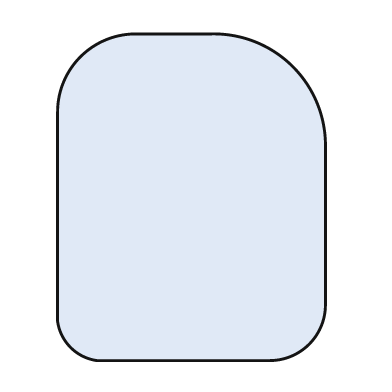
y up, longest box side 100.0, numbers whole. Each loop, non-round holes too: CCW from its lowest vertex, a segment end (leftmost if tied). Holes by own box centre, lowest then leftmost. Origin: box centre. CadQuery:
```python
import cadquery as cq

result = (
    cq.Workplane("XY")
    .moveTo(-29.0, -50.0)
    .lineTo(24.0, -50.0)
    .threePointArc((36.0, -45.0), (41.0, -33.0))
    .lineTo(41.0, 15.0)
    .threePointArc((31.0, 40.0), (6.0, 50.0))
    .lineTo(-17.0, 50.0)
    .threePointArc((-34.0, 43.0), (-41.0, 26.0))
    .lineTo(-41.0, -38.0)
    .threePointArc((-37.0, -46.0), (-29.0, -50.0))
    .close()
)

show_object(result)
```